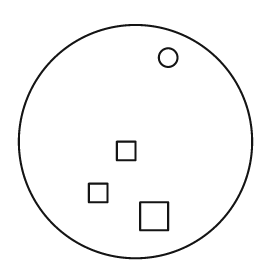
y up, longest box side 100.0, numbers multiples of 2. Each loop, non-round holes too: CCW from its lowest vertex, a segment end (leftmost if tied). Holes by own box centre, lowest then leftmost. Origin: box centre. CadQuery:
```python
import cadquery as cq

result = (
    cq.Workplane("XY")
    .moveTo(0.0, 0.0)
    .circle(50.0)
    .moveTo(2.0, -38.0)
    .lineTo(14.0, -38.0)
    .lineTo(14.0, -26.0)
    .lineTo(2.0, -26.0)
    .close()
    .moveTo(-20.0, -26.0)
    .lineTo(-12.0, -26.0)
    .lineTo(-12.0, -18.0)
    .lineTo(-20.0, -18.0)
    .close()
    .moveTo(-8.0, -8.0)
    .lineTo(0.0, -8.0)
    .lineTo(0.0, 0.0)
    .lineTo(-8.0, 0.0)
    .close()
    .moveTo(14.0, 36.0)
    .circle(4.0)
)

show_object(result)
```